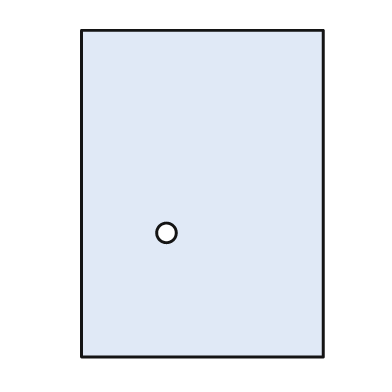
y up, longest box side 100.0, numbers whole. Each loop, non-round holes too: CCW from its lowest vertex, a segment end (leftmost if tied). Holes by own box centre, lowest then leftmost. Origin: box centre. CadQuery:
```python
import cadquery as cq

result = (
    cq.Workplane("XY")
    .moveTo(-37.0, -50.0)
    .lineTo(37.0, -50.0)
    .lineTo(37.0, 50.0)
    .lineTo(-37.0, 50.0)
    .close()
    .moveTo(-11.0, -12.0)
    .circle(3.0)
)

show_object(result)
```